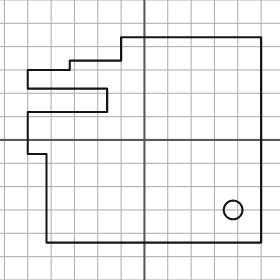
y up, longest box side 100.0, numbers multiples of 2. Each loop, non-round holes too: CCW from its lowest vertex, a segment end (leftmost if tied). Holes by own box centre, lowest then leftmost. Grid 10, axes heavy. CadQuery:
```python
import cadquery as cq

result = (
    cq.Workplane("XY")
    .moveTo(-42.0, -44.0)
    .lineTo(50.0, -44.0)
    .lineTo(50.0, 44.0)
    .lineTo(-10.0, 44.0)
    .lineTo(-10.0, 34.0)
    .lineTo(-32.0, 34.0)
    .lineTo(-32.0, 30.0)
    .lineTo(-50.0, 30.0)
    .lineTo(-50.0, 22.0)
    .lineTo(-16.0, 22.0)
    .lineTo(-16.0, 12.0)
    .lineTo(-50.0, 12.0)
    .lineTo(-50.0, -6.0)
    .lineTo(-42.0, -6.0)
    .close()
    .moveTo(38.0, -30.0)
    .circle(4.0)
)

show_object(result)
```